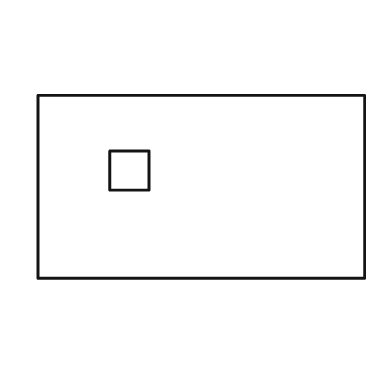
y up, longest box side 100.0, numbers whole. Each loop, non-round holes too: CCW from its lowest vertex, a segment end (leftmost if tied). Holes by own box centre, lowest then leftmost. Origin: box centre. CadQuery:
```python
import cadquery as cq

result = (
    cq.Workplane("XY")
    .moveTo(-50.0, -28.0)
    .lineTo(50.0, -28.0)
    .lineTo(50.0, 28.0)
    .lineTo(-50.0, 28.0)
    .close()
    .moveTo(-28.0, -1.0)
    .lineTo(-16.0, -1.0)
    .lineTo(-16.0, 11.0)
    .lineTo(-28.0, 11.0)
    .close()
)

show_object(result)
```